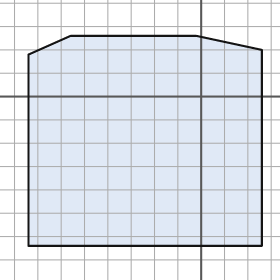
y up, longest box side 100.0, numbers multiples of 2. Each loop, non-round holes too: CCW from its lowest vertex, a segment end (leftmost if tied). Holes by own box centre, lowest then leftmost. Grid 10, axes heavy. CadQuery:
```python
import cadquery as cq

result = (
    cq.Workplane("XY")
    .moveTo(-74.0, -64.0)
    .lineTo(26.0, -64.0)
    .lineTo(26.0, 20.0)
    .lineTo(-2.0, 26.0)
    .lineTo(-56.0, 26.0)
    .lineTo(-74.0, 18.0)
    .close()
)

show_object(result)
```